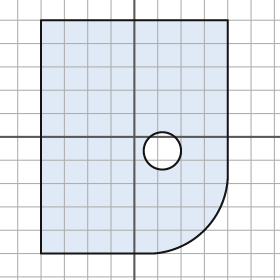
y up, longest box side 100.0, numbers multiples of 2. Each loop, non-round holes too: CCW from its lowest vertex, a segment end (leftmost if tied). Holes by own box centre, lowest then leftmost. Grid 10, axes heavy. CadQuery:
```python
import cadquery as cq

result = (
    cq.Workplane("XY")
    .moveTo(-40.0, -50.0)
    .lineTo(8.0, -50.0)
    .threePointArc((30.0, -40.0), (40.0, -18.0))
    .lineTo(40.0, 50.0)
    .lineTo(-40.0, 50.0)
    .close()
    .moveTo(12.0, -6.0)
    .circle(8.0)
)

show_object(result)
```